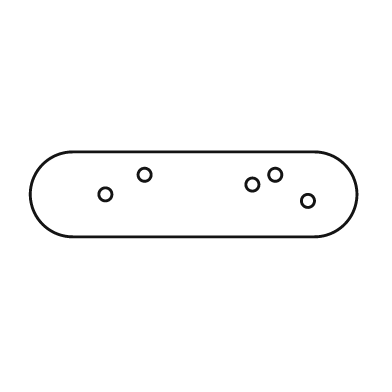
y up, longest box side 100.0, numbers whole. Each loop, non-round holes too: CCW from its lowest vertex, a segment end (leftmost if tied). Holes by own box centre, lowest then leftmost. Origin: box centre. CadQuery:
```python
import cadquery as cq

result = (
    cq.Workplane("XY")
    .moveTo(-37.0, -13.0)
    .lineTo(37.0, -13.0)
    .threePointArc((50.0, 0.0), (37.0, 13.0))
    .lineTo(-37.0, 13.0)
    .threePointArc((-50.0, 0.0), (-37.0, -13.0))
    .close()
    .moveTo(35.0, -2.0)
    .circle(2.0)
    .moveTo(-27.0, 0.0)
    .circle(2.0)
    .moveTo(18.0, 3.0)
    .circle(2.0)
    .moveTo(-15.0, 6.0)
    .circle(2.0)
    .moveTo(25.0, 6.0)
    .circle(2.0)
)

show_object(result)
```